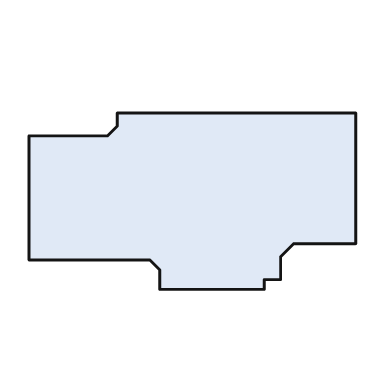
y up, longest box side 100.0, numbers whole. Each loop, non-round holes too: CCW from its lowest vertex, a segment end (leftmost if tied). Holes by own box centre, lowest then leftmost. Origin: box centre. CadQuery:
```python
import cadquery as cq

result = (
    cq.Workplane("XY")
    .moveTo(-10.0, -27.0)
    .lineTo(22.0, -27.0)
    .lineTo(22.0, -24.0)
    .lineTo(27.0, -24.0)
    .lineTo(27.0, -17.0)
    .lineTo(31.0, -13.0)
    .lineTo(50.0, -13.0)
    .lineTo(50.0, 27.0)
    .lineTo(-23.0, 27.0)
    .lineTo(-23.0, 23.0)
    .lineTo(-26.0, 20.0)
    .lineTo(-50.0, 20.0)
    .lineTo(-50.0, -18.0)
    .lineTo(-13.0, -18.0)
    .lineTo(-10.0, -21.0)
    .close()
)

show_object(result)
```